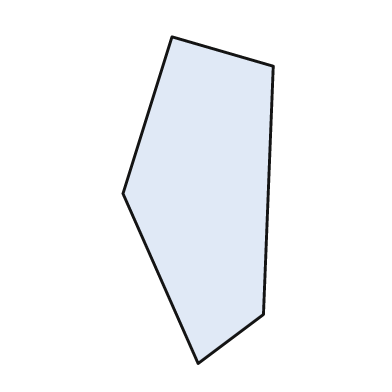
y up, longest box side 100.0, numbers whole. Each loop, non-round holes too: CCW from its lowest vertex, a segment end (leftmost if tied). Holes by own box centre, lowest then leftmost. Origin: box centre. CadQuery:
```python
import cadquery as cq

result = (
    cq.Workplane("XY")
    .moveTo(0.0, -50.0)
    .lineTo(20.0, -35.0)
    .lineTo(23.0, 41.0)
    .lineTo(-8.0, 50.0)
    .lineTo(-23.0, 2.0)
    .close()
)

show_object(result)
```